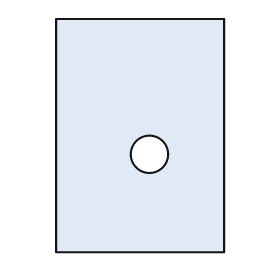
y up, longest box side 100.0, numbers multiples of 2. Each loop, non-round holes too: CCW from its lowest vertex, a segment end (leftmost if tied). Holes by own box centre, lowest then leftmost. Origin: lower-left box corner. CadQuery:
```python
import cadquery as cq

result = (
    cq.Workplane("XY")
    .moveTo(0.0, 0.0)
    .lineTo(72.0, 0.0)
    .lineTo(72.0, 100.0)
    .lineTo(0.0, 100.0)
    .close()
    .moveTo(40.0, 42.0)
    .circle(8.0)
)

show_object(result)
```